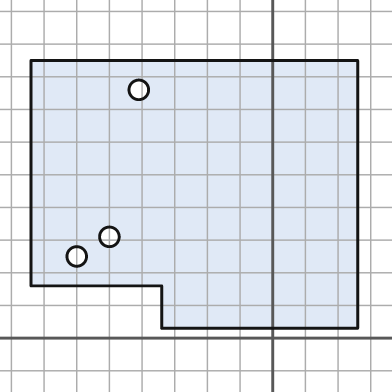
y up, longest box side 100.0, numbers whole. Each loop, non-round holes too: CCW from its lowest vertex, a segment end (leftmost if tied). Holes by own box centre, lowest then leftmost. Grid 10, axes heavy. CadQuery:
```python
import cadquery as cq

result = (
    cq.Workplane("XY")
    .moveTo(-34.0, 3.0)
    .lineTo(26.0, 3.0)
    .lineTo(26.0, 85.0)
    .lineTo(-74.0, 85.0)
    .lineTo(-74.0, 16.0)
    .lineTo(-34.0, 16.0)
    .close()
    .moveTo(-60.0, 25.0)
    .circle(3.0)
    .moveTo(-50.0, 31.0)
    .circle(3.0)
    .moveTo(-41.0, 76.0)
    .circle(3.0)
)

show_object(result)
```